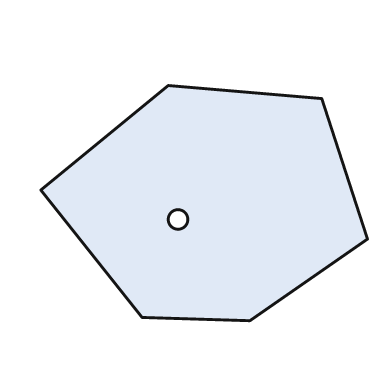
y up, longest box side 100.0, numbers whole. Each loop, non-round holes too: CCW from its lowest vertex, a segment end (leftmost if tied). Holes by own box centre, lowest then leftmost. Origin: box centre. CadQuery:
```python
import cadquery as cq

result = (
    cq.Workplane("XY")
    .moveTo(14.0, -36.0)
    .lineTo(50.0, -11.0)
    .lineTo(36.0, 32.0)
    .lineTo(-11.0, 36.0)
    .lineTo(-50.0, 4.0)
    .lineTo(-19.0, -35.0)
    .close()
    .moveTo(-8.0, -5.0)
    .circle(3.0)
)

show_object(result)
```